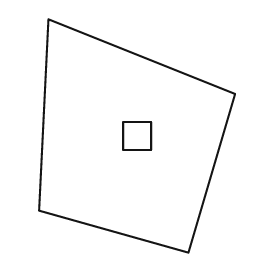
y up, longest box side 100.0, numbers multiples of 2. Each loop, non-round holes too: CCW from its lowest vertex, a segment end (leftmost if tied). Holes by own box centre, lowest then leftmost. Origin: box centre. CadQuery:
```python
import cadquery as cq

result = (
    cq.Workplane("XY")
    .moveTo(22.0, -50.0)
    .lineTo(42.0, 18.0)
    .lineTo(-38.0, 50.0)
    .lineTo(-42.0, -32.0)
    .close()
    .moveTo(-6.0, -6.0)
    .lineTo(6.0, -6.0)
    .lineTo(6.0, 6.0)
    .lineTo(-6.0, 6.0)
    .close()
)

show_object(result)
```